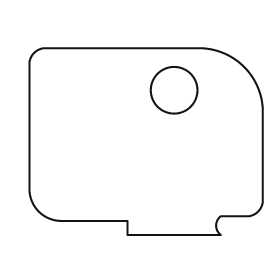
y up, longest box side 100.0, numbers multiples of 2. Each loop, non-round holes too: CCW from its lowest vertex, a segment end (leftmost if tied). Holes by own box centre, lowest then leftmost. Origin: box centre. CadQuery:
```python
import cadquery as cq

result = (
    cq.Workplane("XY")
    .moveTo(-8.0, -40.0)
    .lineTo(32.0, -40.0)
    .threePointArc((30.0, -36.0), (32.0, -32.0))
    .lineTo(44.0, -32.0)
    .threePointArc((48.0, -30.0), (50.0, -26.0))
    .lineTo(50.0, 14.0)
    .threePointArc((42.0, 32.0), (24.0, 40.0))
    .lineTo(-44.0, 40.0)
    .threePointArc((-48.0, 38.0), (-50.0, 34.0))
    .lineTo(-50.0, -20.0)
    .threePointArc((-46.0, -30.0), (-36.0, -34.0))
    .lineTo(-8.0, -34.0)
    .close()
    .moveTo(12.0, 22.0)
    .circle(10.0)
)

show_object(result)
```